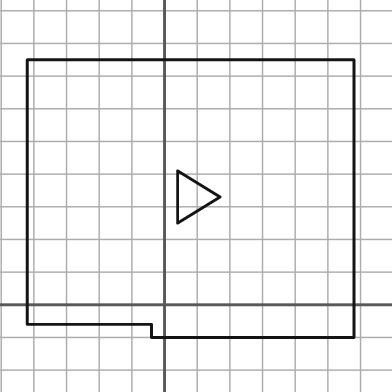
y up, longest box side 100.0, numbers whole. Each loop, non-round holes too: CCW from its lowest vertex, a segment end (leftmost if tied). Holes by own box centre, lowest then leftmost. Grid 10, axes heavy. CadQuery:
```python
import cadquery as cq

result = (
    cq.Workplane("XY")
    .moveTo(-4.0, -10.0)
    .lineTo(58.0, -10.0)
    .lineTo(58.0, 75.0)
    .lineTo(-42.0, 75.0)
    .lineTo(-42.0, -6.0)
    .lineTo(-4.0, -6.0)
    .close()
    .moveTo(4.0, 25.0)
    .lineTo(17.0, 33.0)
    .lineTo(4.0, 41.0)
    .close()
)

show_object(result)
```